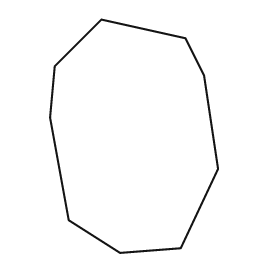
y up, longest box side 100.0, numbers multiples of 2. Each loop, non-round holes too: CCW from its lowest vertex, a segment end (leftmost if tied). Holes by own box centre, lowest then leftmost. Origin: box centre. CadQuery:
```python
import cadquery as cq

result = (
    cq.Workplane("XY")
    .moveTo(-6.0, -50.0)
    .lineTo(20.0, -48.0)
    .lineTo(36.0, -14.0)
    .lineTo(30.0, 26.0)
    .lineTo(22.0, 42.0)
    .lineTo(-14.0, 50.0)
    .lineTo(-34.0, 30.0)
    .lineTo(-36.0, 8.0)
    .lineTo(-28.0, -36.0)
    .close()
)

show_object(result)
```